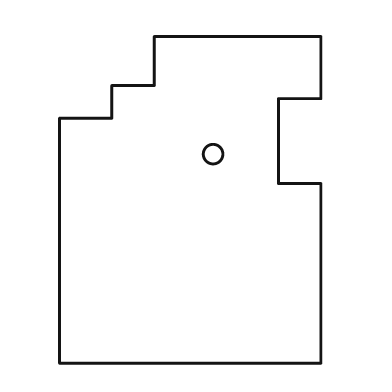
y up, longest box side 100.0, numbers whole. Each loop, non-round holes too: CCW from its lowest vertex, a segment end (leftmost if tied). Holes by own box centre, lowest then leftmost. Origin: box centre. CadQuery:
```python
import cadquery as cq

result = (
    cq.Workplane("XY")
    .moveTo(-40.0, -50.0)
    .lineTo(40.0, -50.0)
    .lineTo(40.0, 5.0)
    .lineTo(27.0, 5.0)
    .lineTo(27.0, 31.0)
    .lineTo(40.0, 31.0)
    .lineTo(40.0, 50.0)
    .lineTo(-11.0, 50.0)
    .lineTo(-11.0, 35.0)
    .lineTo(-24.0, 35.0)
    .lineTo(-24.0, 25.0)
    .lineTo(-40.0, 25.0)
    .close()
    .moveTo(7.0, 14.0)
    .circle(3.0)
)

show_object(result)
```